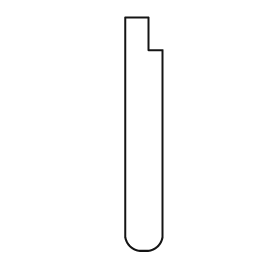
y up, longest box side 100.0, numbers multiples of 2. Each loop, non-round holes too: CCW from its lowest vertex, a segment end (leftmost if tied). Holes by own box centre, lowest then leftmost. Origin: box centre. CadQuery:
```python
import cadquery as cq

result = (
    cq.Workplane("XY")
    .moveTo(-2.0, -50.0)
    .lineTo(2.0, -50.0)
    .threePointArc((6.0, -48.0), (8.0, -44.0))
    .lineTo(8.0, 36.0)
    .lineTo(2.0, 36.0)
    .lineTo(2.0, 50.0)
    .lineTo(-8.0, 50.0)
    .lineTo(-8.0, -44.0)
    .threePointArc((-6.0, -48.0), (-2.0, -50.0))
    .close()
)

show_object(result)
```